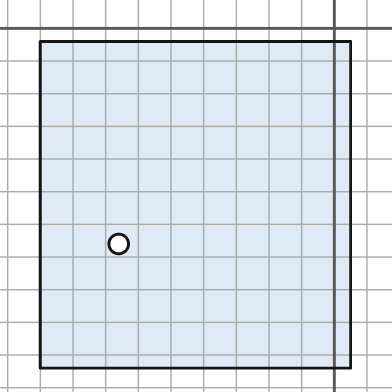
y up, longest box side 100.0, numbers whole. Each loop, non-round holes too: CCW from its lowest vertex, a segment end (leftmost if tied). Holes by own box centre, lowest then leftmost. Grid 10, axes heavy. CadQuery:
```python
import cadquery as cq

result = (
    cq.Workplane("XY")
    .moveTo(-90.0, -104.0)
    .lineTo(5.0, -104.0)
    .lineTo(5.0, -4.0)
    .lineTo(-90.0, -4.0)
    .close()
    .moveTo(-66.0, -66.0)
    .circle(3.0)
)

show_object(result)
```